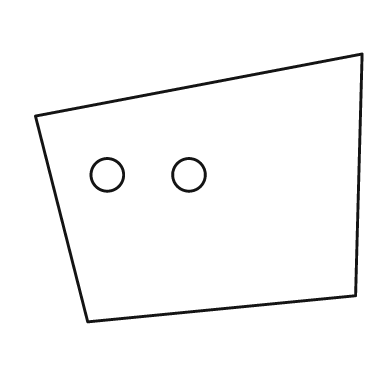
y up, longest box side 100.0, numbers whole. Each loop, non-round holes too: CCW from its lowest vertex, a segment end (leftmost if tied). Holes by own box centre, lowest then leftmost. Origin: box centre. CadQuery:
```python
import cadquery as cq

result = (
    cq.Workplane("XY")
    .moveTo(-34.0, -41.0)
    .lineTo(48.0, -33.0)
    .lineTo(50.0, 41.0)
    .lineTo(-50.0, 22.0)
    .close()
    .moveTo(-28.0, 4.0)
    .circle(5.0)
    .moveTo(-3.0, 4.0)
    .circle(5.0)
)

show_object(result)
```